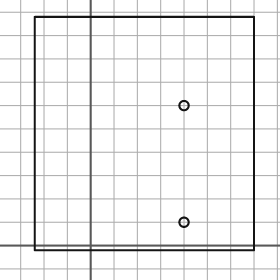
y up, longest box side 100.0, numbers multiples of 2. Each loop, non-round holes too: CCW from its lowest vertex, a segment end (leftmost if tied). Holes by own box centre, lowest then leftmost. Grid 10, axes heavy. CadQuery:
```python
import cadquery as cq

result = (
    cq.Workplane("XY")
    .moveTo(-24.0, -2.0)
    .lineTo(70.0, -2.0)
    .lineTo(70.0, 98.0)
    .lineTo(-24.0, 98.0)
    .close()
    .moveTo(40.0, 10.0)
    .circle(2.0)
    .moveTo(40.0, 60.0)
    .circle(2.0)
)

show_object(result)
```